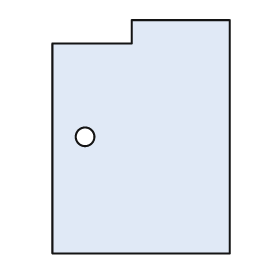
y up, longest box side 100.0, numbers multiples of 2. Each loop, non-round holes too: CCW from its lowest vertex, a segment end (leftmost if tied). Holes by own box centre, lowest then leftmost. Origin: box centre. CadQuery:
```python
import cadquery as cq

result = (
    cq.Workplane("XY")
    .moveTo(-38.0, -50.0)
    .lineTo(38.0, -50.0)
    .lineTo(38.0, 50.0)
    .lineTo(-4.0, 50.0)
    .lineTo(-4.0, 40.0)
    .lineTo(-38.0, 40.0)
    .close()
    .moveTo(-24.0, 0.0)
    .circle(4.0)
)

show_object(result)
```